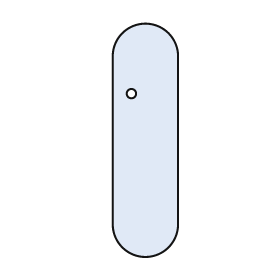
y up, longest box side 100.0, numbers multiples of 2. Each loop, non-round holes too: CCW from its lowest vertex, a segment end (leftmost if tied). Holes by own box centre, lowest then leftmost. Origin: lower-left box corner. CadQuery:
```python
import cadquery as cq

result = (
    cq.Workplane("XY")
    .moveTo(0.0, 14.0)
    .threePointArc((14.0, 0.0), (28.0, 14.0))
    .lineTo(28.0, 86.0)
    .threePointArc((14.0, 100.0), (0.0, 86.0))
    .close()
    .moveTo(8.0, 70.0)
    .circle(2.0)
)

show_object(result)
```